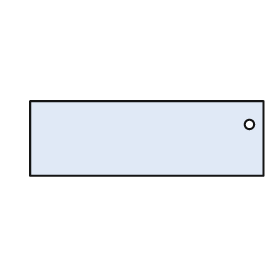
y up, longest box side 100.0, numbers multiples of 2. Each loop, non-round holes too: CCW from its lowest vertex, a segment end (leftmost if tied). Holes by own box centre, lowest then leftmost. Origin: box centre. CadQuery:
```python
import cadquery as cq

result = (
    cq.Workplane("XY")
    .moveTo(-50.0, -16.0)
    .lineTo(50.0, -16.0)
    .lineTo(50.0, 16.0)
    .lineTo(-50.0, 16.0)
    .close()
    .moveTo(44.0, 6.0)
    .circle(2.0)
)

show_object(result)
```